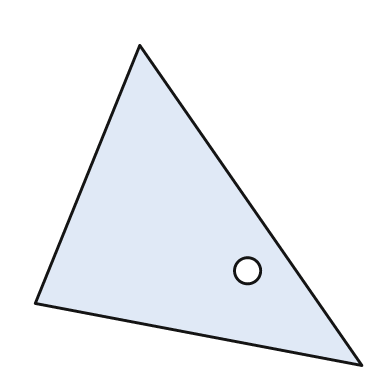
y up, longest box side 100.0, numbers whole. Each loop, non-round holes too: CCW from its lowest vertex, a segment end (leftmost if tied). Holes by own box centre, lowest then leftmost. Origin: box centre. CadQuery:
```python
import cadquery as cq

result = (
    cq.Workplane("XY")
    .moveTo(50.0, -49.0)
    .lineTo(-18.0, 49.0)
    .lineTo(-50.0, -30.0)
    .close()
    .moveTo(15.0, -20.0)
    .circle(4.0)
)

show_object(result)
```